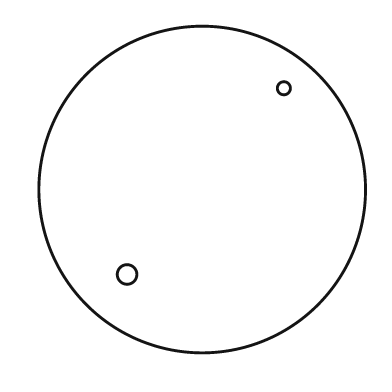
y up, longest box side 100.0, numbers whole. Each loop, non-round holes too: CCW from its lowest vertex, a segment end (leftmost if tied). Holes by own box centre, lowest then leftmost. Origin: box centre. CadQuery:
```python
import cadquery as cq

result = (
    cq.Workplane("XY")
    .moveTo(0.0, 0.0)
    .circle(50.0)
    .moveTo(-23.0, -26.0)
    .circle(3.0)
    .moveTo(25.0, 31.0)
    .circle(2.0)
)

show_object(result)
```